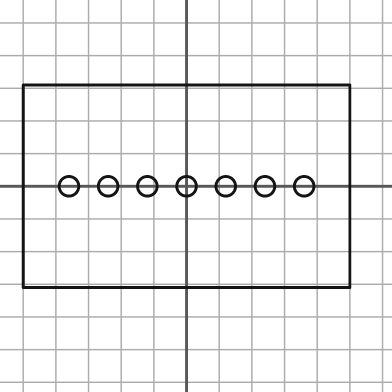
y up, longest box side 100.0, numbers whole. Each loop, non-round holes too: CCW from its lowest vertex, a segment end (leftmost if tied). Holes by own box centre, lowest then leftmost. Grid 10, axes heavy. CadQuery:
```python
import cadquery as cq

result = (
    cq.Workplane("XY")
    .moveTo(-50.0, -31.0)
    .lineTo(50.0, -31.0)
    .lineTo(50.0, 31.0)
    .lineTo(-50.0, 31.0)
    .close()
    .moveTo(-36.0, 0.0)
    .circle(3.0)
    .moveTo(-24.0, 0.0)
    .circle(3.0)
    .moveTo(-12.0, 0.0)
    .circle(3.0)
    .moveTo(0.0, 0.0)
    .circle(3.0)
    .moveTo(12.0, 0.0)
    .circle(3.0)
    .moveTo(24.0, 0.0)
    .circle(3.0)
    .moveTo(36.0, 0.0)
    .circle(3.0)
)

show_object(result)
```